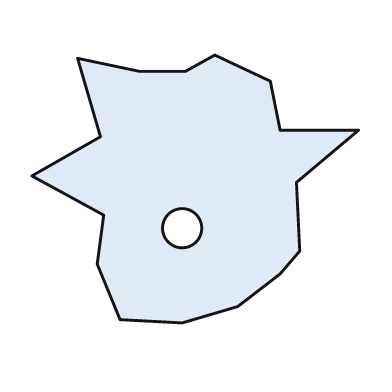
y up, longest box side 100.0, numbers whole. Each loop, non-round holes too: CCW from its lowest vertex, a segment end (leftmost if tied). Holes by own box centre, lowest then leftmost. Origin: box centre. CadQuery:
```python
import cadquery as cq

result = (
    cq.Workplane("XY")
    .moveTo(-4.0, -41.0)
    .lineTo(13.0, -36.0)
    .lineTo(26.0, -26.0)
    .lineTo(32.0, -19.0)
    .lineTo(31.0, 2.0)
    .lineTo(50.0, 18.0)
    .lineTo(26.0, 18.0)
    .lineTo(23.0, 33.0)
    .lineTo(6.0, 41.0)
    .lineTo(-3.0, 36.0)
    .lineTo(-17.0, 36.0)
    .lineTo(-36.0, 40.0)
    .lineTo(-29.0, 16.0)
    .lineTo(-50.0, 4.0)
    .lineTo(-28.0, -8.0)
    .lineTo(-30.0, -23.0)
    .lineTo(-23.0, -40.0)
    .close()
    .moveTo(-4.0, -12.0)
    .circle(6.0)
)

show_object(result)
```